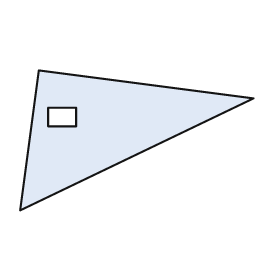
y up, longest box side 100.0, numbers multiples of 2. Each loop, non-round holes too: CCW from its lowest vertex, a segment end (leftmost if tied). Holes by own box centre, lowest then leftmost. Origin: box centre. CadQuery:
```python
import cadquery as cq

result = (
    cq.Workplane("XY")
    .moveTo(-50.0, -30.0)
    .lineTo(50.0, 18.0)
    .lineTo(-42.0, 30.0)
    .close()
    .moveTo(-38.0, 6.0)
    .lineTo(-26.0, 6.0)
    .lineTo(-26.0, 14.0)
    .lineTo(-38.0, 14.0)
    .close()
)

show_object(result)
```